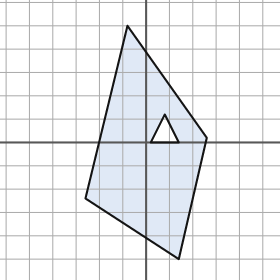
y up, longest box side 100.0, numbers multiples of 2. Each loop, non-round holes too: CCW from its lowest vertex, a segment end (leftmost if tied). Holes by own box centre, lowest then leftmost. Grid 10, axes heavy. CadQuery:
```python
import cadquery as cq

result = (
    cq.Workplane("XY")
    .moveTo(14.0, -50.0)
    .lineTo(26.0, 2.0)
    .lineTo(-8.0, 50.0)
    .lineTo(-26.0, -24.0)
    .close()
    .moveTo(2.0, 0.0)
    .lineTo(14.0, 0.0)
    .lineTo(8.0, 12.0)
    .close()
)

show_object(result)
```